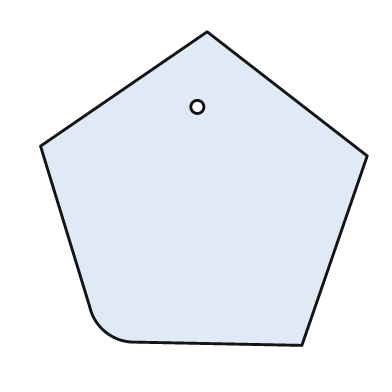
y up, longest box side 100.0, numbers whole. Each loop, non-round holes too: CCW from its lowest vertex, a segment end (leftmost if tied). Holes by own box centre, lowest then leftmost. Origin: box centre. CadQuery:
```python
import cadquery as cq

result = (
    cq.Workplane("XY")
    .moveTo(30.0, -48.0)
    .lineTo(50.0, 10.0)
    .lineTo(1.0, 48.0)
    .lineTo(-50.0, 13.0)
    .lineTo(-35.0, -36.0)
    .threePointArc((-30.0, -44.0), (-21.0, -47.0))
    .close()
    .moveTo(-2.0, 25.0)
    .circle(2.0)
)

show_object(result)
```